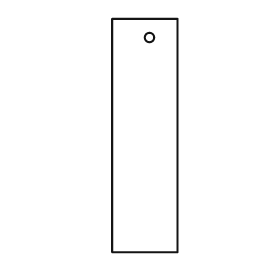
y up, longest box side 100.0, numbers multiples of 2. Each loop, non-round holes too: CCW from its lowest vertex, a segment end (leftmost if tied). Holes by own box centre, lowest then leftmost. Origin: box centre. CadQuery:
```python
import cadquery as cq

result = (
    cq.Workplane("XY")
    .moveTo(-14.0, -50.0)
    .lineTo(14.0, -50.0)
    .lineTo(14.0, 50.0)
    .lineTo(-14.0, 50.0)
    .close()
    .moveTo(2.0, 42.0)
    .circle(2.0)
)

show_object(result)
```